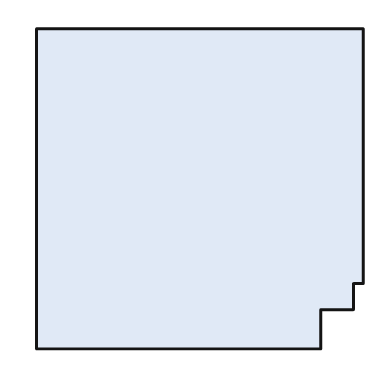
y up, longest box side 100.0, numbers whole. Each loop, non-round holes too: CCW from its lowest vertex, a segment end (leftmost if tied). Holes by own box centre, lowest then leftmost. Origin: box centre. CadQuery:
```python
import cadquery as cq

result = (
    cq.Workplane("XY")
    .moveTo(-50.0, -49.0)
    .lineTo(37.0, -49.0)
    .lineTo(37.0, -37.0)
    .lineTo(47.0, -37.0)
    .lineTo(47.0, -29.0)
    .lineTo(50.0, -29.0)
    .lineTo(50.0, 49.0)
    .lineTo(-50.0, 49.0)
    .close()
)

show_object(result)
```